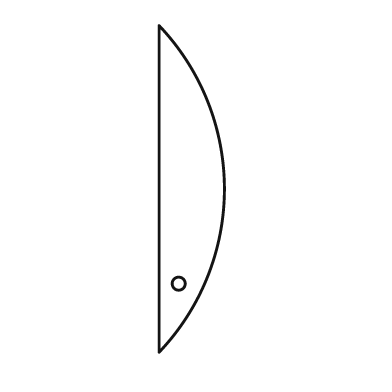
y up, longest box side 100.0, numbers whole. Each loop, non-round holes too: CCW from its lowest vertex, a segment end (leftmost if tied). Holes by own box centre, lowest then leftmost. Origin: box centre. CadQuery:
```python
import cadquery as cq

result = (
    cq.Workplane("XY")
    .moveTo(-10.0, -50.0)
    .threePointArc((10.0, 0.0), (-10.0, 50.0))
    .close()
    .moveTo(-4.0, -29.0)
    .circle(2.0)
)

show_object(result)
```